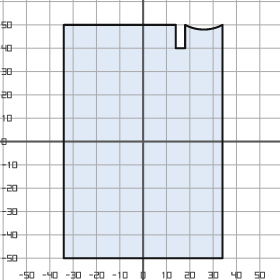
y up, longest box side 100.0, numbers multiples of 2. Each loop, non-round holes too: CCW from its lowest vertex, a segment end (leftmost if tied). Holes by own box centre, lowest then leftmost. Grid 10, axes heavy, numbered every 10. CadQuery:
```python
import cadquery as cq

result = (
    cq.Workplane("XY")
    .moveTo(-34.0, -50.0)
    .lineTo(34.0, -50.0)
    .lineTo(34.0, 50.0)
    .threePointArc((26.0, 48.0), (18.0, 50.0))
    .lineTo(18.0, 40.0)
    .lineTo(14.0, 40.0)
    .lineTo(14.0, 50.0)
    .lineTo(-34.0, 50.0)
    .close()
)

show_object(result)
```